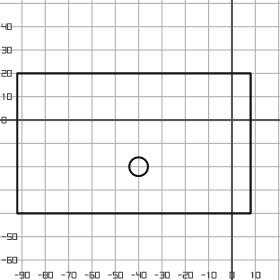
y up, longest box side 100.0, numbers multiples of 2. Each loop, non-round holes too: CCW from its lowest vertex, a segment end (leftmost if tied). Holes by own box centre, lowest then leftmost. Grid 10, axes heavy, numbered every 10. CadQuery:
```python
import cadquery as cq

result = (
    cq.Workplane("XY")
    .moveTo(-92.0, -40.0)
    .lineTo(8.0, -40.0)
    .lineTo(8.0, 20.0)
    .lineTo(-92.0, 20.0)
    .close()
    .moveTo(-40.0, -20.0)
    .circle(4.0)
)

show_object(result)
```